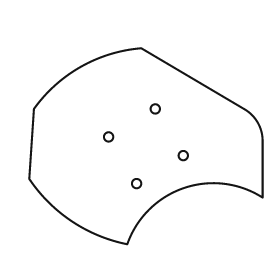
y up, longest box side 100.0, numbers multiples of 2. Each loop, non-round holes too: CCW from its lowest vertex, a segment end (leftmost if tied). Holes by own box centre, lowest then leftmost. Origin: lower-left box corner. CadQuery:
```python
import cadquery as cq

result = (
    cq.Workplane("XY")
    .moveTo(42.0, 0.0)
    .threePointArc((66.0, 24.0), (100.0, 20.0))
    .lineTo(100.0, 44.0)
    .threePointArc((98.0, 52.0), (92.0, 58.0))
    .lineTo(48.0, 84.0)
    .threePointArc((22.0, 76.0), (2.0, 58.0))
    .lineTo(0.0, 28.0)
    .threePointArc((18.0, 10.0), (42.0, 0.0))
    .close()
    .moveTo(46.0, 26.0)
    .circle(2.0)
    .moveTo(66.0, 38.0)
    .circle(2.0)
    .moveTo(34.0, 46.0)
    .circle(2.0)
    .moveTo(54.0, 58.0)
    .circle(2.0)
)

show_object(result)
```